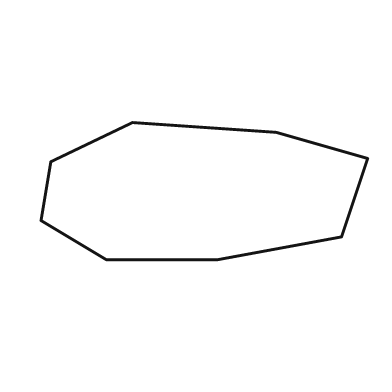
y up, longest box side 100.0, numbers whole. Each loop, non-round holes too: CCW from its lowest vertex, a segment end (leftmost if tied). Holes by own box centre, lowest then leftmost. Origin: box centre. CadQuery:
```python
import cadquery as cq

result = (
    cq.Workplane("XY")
    .moveTo(-30.0, -21.0)
    .lineTo(4.0, -21.0)
    .lineTo(42.0, -14.0)
    .lineTo(50.0, 10.0)
    .lineTo(22.0, 18.0)
    .lineTo(-22.0, 21.0)
    .lineTo(-47.0, 9.0)
    .lineTo(-50.0, -9.0)
    .close()
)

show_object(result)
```